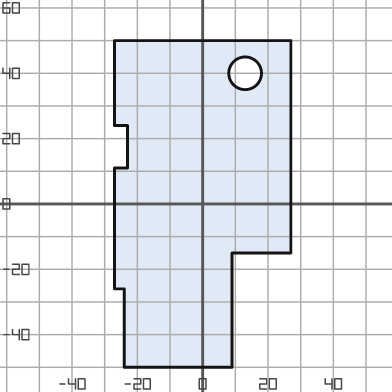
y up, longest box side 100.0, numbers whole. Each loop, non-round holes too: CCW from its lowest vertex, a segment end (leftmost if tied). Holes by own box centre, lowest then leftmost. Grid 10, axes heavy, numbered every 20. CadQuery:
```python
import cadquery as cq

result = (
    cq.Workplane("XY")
    .moveTo(-24.0, -50.0)
    .lineTo(9.0, -50.0)
    .lineTo(9.0, -15.0)
    .lineTo(27.0, -15.0)
    .lineTo(27.0, 50.0)
    .lineTo(-27.0, 50.0)
    .lineTo(-27.0, 24.0)
    .lineTo(-23.0, 24.0)
    .lineTo(-23.0, 11.0)
    .lineTo(-27.0, 11.0)
    .lineTo(-27.0, -26.0)
    .lineTo(-24.0, -26.0)
    .close()
    .moveTo(13.0, 40.0)
    .circle(5.0)
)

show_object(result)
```